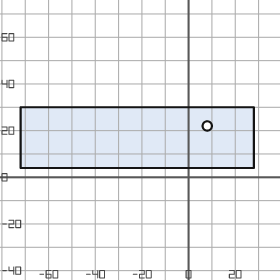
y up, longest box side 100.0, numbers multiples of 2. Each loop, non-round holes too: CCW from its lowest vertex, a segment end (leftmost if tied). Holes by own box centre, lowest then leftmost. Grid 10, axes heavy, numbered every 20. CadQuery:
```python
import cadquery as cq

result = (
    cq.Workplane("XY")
    .moveTo(-72.0, 4.0)
    .lineTo(28.0, 4.0)
    .lineTo(28.0, 30.0)
    .lineTo(-72.0, 30.0)
    .close()
    .moveTo(8.0, 22.0)
    .circle(2.0)
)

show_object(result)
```